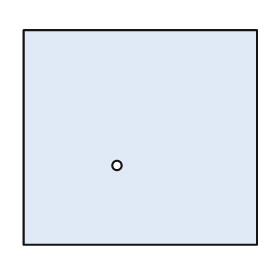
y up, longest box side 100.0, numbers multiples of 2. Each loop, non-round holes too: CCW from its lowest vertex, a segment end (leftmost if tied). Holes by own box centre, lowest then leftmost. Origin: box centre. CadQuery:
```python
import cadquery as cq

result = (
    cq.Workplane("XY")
    .moveTo(-50.0, -46.0)
    .lineTo(50.0, -46.0)
    .lineTo(50.0, 46.0)
    .lineTo(-50.0, 46.0)
    .close()
    .moveTo(-10.0, -12.0)
    .circle(2.0)
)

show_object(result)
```